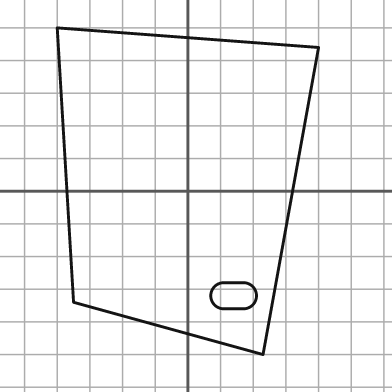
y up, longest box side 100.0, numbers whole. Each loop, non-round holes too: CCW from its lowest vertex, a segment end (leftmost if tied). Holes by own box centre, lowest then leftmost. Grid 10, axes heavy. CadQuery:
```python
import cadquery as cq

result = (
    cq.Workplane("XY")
    .moveTo(23.0, -50.0)
    .lineTo(40.0, 44.0)
    .lineTo(-40.0, 50.0)
    .lineTo(-35.0, -34.0)
    .close()
    .moveTo(11.0, -36.0)
    .lineTo(17.0, -36.0)
    .threePointArc((21.0, -32.0), (17.0, -28.0))
    .lineTo(11.0, -28.0)
    .threePointArc((7.0, -32.0), (11.0, -36.0))
    .close()
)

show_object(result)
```